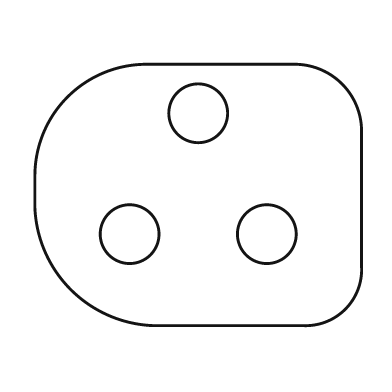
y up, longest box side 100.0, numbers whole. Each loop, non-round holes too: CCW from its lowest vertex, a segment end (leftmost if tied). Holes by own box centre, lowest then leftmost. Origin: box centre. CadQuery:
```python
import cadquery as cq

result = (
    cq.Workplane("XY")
    .moveTo(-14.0, -40.0)
    .lineTo(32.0, -40.0)
    .threePointArc((45.0, -35.0), (50.0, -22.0))
    .lineTo(50.0, 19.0)
    .threePointArc((44.0, 34.0), (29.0, 40.0))
    .lineTo(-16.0, 40.0)
    .threePointArc((-40.0, 30.0), (-50.0, 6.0))
    .lineTo(-50.0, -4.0)
    .threePointArc((-39.0, -29.0), (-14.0, -40.0))
    .close()
    .moveTo(-21.0, -12.0)
    .circle(9.0)
    .moveTo(21.0, -12.0)
    .circle(9.0)
    .moveTo(0.0, 25.0)
    .circle(9.0)
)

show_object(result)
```